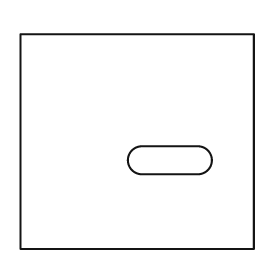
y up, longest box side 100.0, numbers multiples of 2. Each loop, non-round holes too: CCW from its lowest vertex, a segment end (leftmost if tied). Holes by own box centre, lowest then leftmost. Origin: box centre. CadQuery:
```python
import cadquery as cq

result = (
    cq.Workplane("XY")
    .moveTo(-50.0, -46.0)
    .lineTo(50.0, -46.0)
    .lineTo(50.0, 46.0)
    .lineTo(-50.0, 46.0)
    .close()
    .moveTo(2.0, -14.0)
    .lineTo(26.0, -14.0)
    .threePointArc((32.0, -8.0), (26.0, -2.0))
    .lineTo(2.0, -2.0)
    .threePointArc((-4.0, -8.0), (2.0, -14.0))
    .close()
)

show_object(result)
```